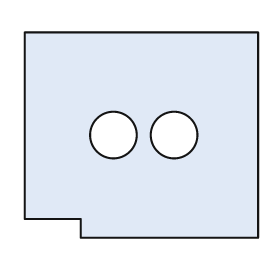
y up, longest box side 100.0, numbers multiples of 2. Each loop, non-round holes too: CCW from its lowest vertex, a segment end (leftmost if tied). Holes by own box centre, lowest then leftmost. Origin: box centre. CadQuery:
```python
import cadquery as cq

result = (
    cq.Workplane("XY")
    .moveTo(-26.0, -44.0)
    .lineTo(50.0, -44.0)
    .lineTo(50.0, 44.0)
    .lineTo(-50.0, 44.0)
    .lineTo(-50.0, -36.0)
    .lineTo(-26.0, -36.0)
    .close()
    .moveTo(-12.0, 0.0)
    .circle(10.0)
    .moveTo(14.0, 0.0)
    .circle(10.0)
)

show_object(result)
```